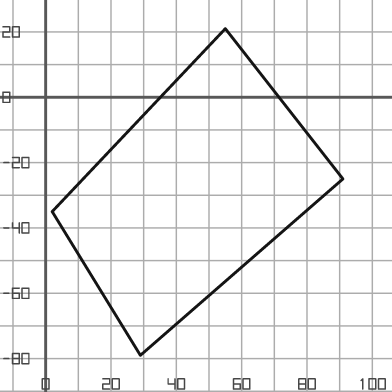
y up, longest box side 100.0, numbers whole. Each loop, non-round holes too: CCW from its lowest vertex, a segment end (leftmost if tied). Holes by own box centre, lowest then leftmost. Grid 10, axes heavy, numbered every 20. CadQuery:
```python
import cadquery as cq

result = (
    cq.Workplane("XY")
    .moveTo(29.0, -79.0)
    .lineTo(91.0, -25.0)
    .lineTo(55.0, 21.0)
    .lineTo(2.0, -35.0)
    .close()
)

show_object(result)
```